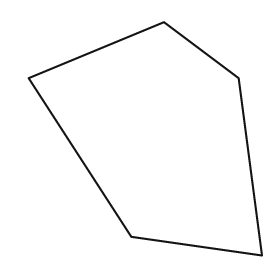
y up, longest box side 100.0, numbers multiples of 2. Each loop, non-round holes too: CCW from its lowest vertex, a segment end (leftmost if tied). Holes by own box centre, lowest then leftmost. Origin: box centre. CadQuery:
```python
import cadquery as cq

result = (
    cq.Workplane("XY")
    .moveTo(50.0, -50.0)
    .lineTo(40.0, 26.0)
    .lineTo(8.0, 50.0)
    .lineTo(-50.0, 26.0)
    .lineTo(-6.0, -42.0)
    .close()
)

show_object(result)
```